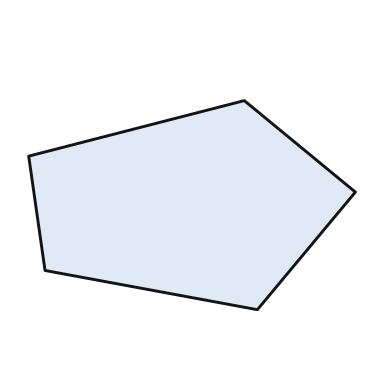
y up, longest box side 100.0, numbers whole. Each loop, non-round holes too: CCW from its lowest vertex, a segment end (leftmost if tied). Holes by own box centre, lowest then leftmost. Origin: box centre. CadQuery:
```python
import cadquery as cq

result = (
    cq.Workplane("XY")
    .moveTo(20.0, -32.0)
    .lineTo(50.0, 4.0)
    .lineTo(16.0, 32.0)
    .lineTo(-50.0, 15.0)
    .lineTo(-45.0, -20.0)
    .close()
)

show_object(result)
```